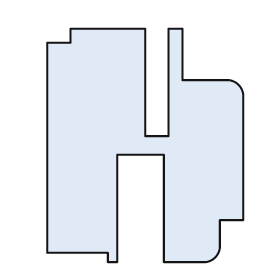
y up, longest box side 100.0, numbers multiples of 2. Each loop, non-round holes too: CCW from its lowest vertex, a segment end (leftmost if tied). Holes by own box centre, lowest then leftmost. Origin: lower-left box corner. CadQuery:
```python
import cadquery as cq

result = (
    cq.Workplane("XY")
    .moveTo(26.0, 0.0)
    .lineTo(30.0, 0.0)
    .lineTo(30.0, 46.0)
    .lineTo(50.0, 46.0)
    .lineTo(50.0, 0.0)
    .lineTo(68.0, 0.0)
    .threePointArc((72.0, 2.0), (74.0, 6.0))
    .lineTo(74.0, 18.0)
    .lineTo(84.0, 18.0)
    .lineTo(84.0, 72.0)
    .threePointArc((82.0, 76.0), (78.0, 78.0))
    .lineTo(58.0, 78.0)
    .lineTo(58.0, 100.0)
    .lineTo(52.0, 100.0)
    .lineTo(52.0, 54.0)
    .lineTo(42.0, 54.0)
    .lineTo(42.0, 100.0)
    .lineTo(10.0, 100.0)
    .lineTo(10.0, 94.0)
    .lineTo(0.0, 94.0)
    .lineTo(0.0, 4.0)
    .lineTo(26.0, 4.0)
    .close()
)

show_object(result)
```